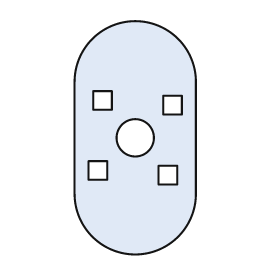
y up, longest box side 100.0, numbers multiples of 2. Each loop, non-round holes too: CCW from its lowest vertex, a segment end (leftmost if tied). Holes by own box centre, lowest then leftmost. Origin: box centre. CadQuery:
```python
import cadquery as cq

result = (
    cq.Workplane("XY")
    .moveTo(-26.0, -24.0)
    .threePointArc((0.0, -50.0), (26.0, -24.0))
    .lineTo(26.0, 24.0)
    .threePointArc((0.0, 50.0), (-26.0, 24.0))
    .close()
    .moveTo(10.0, -20.0)
    .lineTo(18.0, -20.0)
    .lineTo(18.0, -12.0)
    .lineTo(10.0, -12.0)
    .close()
    .moveTo(-20.0, -18.0)
    .lineTo(-12.0, -18.0)
    .lineTo(-12.0, -10.0)
    .lineTo(-20.0, -10.0)
    .close()
    .moveTo(0.0, 0.0)
    .circle(8.0)
    .moveTo(12.0, 10.0)
    .lineTo(20.0, 10.0)
    .lineTo(20.0, 18.0)
    .lineTo(12.0, 18.0)
    .close()
    .moveTo(-18.0, 12.0)
    .lineTo(-10.0, 12.0)
    .lineTo(-10.0, 20.0)
    .lineTo(-18.0, 20.0)
    .close()
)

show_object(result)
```